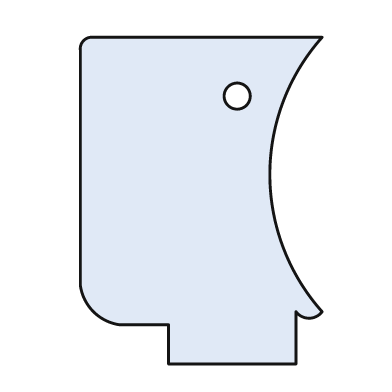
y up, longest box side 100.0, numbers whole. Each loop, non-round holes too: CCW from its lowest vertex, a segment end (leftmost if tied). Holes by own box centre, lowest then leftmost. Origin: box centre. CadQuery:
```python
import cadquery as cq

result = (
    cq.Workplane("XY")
    .moveTo(-10.0, -50.0)
    .lineTo(29.0, -50.0)
    .lineTo(29.0, -34.0)
    .threePointArc((33.0, -36.0), (37.0, -34.0))
    .threePointArc((21.0, 8.0), (37.0, 50.0))
    .lineTo(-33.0, 50.0)
    .threePointArc((-36.0, 49.0), (-37.0, 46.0))
    .lineTo(-37.0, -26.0)
    .threePointArc((-33.0, -34.0), (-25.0, -38.0))
    .lineTo(-10.0, -38.0)
    .close()
    .moveTo(11.0, 32.0)
    .circle(4.0)
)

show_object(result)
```